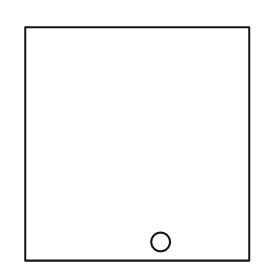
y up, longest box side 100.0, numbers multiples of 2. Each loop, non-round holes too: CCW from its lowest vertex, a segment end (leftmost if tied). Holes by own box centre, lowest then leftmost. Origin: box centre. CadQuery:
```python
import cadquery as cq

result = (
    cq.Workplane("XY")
    .moveTo(-48.0, -50.0)
    .lineTo(48.0, -50.0)
    .lineTo(48.0, 50.0)
    .lineTo(-48.0, 50.0)
    .close()
    .moveTo(10.0, -42.0)
    .circle(4.0)
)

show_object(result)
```